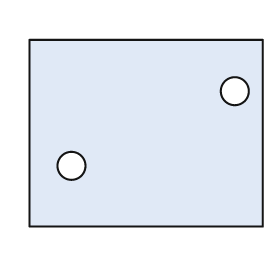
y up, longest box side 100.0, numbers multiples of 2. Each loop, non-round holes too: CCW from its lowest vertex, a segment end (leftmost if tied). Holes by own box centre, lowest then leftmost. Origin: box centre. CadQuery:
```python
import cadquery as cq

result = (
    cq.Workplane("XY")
    .moveTo(-50.0, -40.0)
    .lineTo(50.0, -40.0)
    .lineTo(50.0, 40.0)
    .lineTo(-50.0, 40.0)
    .close()
    .moveTo(-32.0, -14.0)
    .circle(6.0)
    .moveTo(38.0, 18.0)
    .circle(6.0)
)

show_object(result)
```